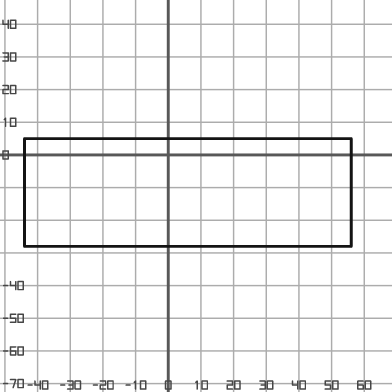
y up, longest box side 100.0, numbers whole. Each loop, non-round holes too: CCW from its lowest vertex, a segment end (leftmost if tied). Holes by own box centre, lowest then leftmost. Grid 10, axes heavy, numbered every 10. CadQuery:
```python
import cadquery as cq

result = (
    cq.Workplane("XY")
    .moveTo(-44.0, -28.0)
    .lineTo(56.0, -28.0)
    .lineTo(56.0, 5.0)
    .lineTo(-44.0, 5.0)
    .close()
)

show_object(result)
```